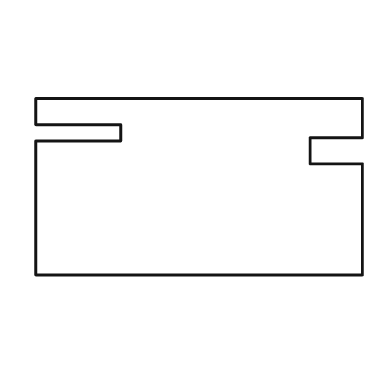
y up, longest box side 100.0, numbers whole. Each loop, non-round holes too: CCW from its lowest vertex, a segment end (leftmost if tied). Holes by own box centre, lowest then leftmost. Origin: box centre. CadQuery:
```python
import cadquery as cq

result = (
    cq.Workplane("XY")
    .moveTo(-50.0, -27.0)
    .lineTo(50.0, -27.0)
    .lineTo(50.0, 7.0)
    .lineTo(34.0, 7.0)
    .lineTo(34.0, 15.0)
    .lineTo(50.0, 15.0)
    .lineTo(50.0, 27.0)
    .lineTo(-50.0, 27.0)
    .lineTo(-50.0, 19.0)
    .lineTo(-24.0, 19.0)
    .lineTo(-24.0, 14.0)
    .lineTo(-50.0, 14.0)
    .close()
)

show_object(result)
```